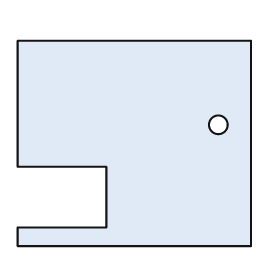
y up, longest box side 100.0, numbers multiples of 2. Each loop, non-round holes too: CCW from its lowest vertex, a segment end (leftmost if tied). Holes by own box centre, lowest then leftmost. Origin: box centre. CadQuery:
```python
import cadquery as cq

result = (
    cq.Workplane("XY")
    .moveTo(-50.0, -44.0)
    .lineTo(50.0, -44.0)
    .lineTo(50.0, 44.0)
    .lineTo(-50.0, 44.0)
    .lineTo(-50.0, -10.0)
    .lineTo(-12.0, -10.0)
    .lineTo(-12.0, -36.0)
    .lineTo(-50.0, -36.0)
    .close()
    .moveTo(36.0, 8.0)
    .circle(4.0)
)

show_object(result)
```